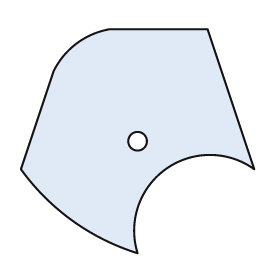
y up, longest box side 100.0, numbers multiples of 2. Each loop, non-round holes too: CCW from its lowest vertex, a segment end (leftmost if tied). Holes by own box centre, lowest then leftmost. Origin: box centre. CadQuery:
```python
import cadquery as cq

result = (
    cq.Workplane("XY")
    .moveTo(0.0, -48.0)
    .threePointArc((12.0, -12.0), (50.0, -12.0))
    .lineTo(30.0, 48.0)
    .lineTo(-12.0, 48.0)
    .threePointArc((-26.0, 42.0), (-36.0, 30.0))
    .lineTo(-50.0, -12.0)
    .threePointArc((-28.0, -34.0), (0.0, -48.0))
    .close()
    .moveTo(0.0, 0.0)
    .circle(4.0)
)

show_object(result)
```